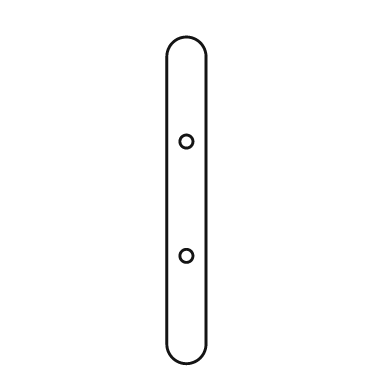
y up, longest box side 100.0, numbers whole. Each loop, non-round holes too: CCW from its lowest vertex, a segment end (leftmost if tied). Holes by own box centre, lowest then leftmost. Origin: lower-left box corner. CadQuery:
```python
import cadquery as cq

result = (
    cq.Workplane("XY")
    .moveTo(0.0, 6.0)
    .threePointArc((6.0, 0.0), (12.0, 6.0))
    .lineTo(12.0, 94.0)
    .threePointArc((6.0, 100.0), (0.0, 94.0))
    .close()
    .moveTo(6.0, 33.0)
    .circle(2.0)
    .moveTo(6.0, 68.0)
    .circle(2.0)
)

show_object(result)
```